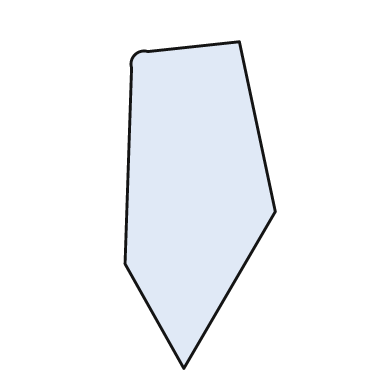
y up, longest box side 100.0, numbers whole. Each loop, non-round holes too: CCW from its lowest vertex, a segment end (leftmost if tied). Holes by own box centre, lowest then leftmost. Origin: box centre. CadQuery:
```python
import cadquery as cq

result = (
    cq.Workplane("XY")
    .moveTo(-5.0, -50.0)
    .lineTo(23.0, -2.0)
    .lineTo(12.0, 50.0)
    .lineTo(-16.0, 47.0)
    .threePointArc((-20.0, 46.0), (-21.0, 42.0))
    .lineTo(-23.0, -18.0)
    .close()
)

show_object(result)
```